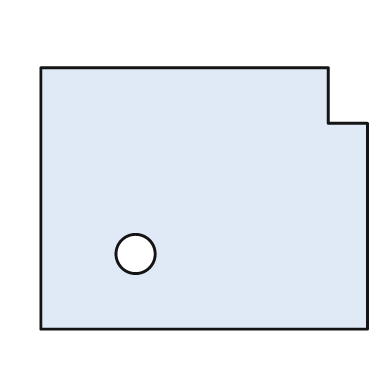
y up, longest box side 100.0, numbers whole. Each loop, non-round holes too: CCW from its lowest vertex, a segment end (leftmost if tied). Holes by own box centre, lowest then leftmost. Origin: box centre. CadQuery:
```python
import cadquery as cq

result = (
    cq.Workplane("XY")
    .moveTo(-50.0, -40.0)
    .lineTo(50.0, -40.0)
    .lineTo(50.0, 23.0)
    .lineTo(38.0, 23.0)
    .lineTo(38.0, 40.0)
    .lineTo(-50.0, 40.0)
    .close()
    .moveTo(-21.0, -17.0)
    .circle(6.0)
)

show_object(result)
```